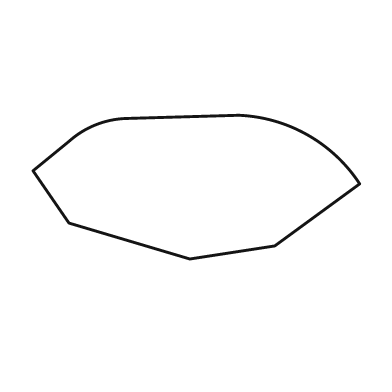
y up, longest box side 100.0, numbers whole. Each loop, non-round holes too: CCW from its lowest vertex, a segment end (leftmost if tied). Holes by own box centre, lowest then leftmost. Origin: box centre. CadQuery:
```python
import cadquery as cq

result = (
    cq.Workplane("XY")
    .moveTo(-2.0, -22.0)
    .lineTo(24.0, -18.0)
    .lineTo(50.0, 1.0)
    .threePointArc((34.0, 16.0), (13.0, 22.0))
    .lineTo(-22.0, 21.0)
    .threePointArc((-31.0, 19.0), (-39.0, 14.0))
    .lineTo(-50.0, 5.0)
    .lineTo(-39.0, -11.0)
    .close()
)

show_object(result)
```